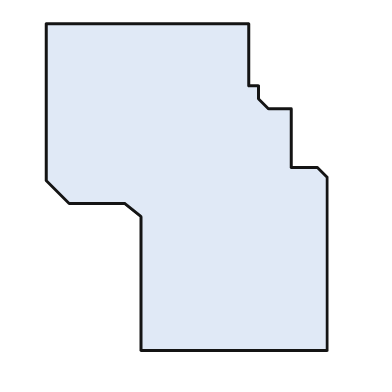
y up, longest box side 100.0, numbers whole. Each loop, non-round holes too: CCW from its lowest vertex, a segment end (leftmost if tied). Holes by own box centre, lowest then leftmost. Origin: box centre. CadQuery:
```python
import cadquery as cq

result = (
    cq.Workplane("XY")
    .moveTo(-14.0, -50.0)
    .lineTo(43.0, -50.0)
    .lineTo(43.0, 3.0)
    .lineTo(40.0, 6.0)
    .lineTo(32.0, 6.0)
    .lineTo(32.0, 24.0)
    .lineTo(25.0, 24.0)
    .lineTo(22.0, 27.0)
    .lineTo(22.0, 31.0)
    .lineTo(19.0, 31.0)
    .lineTo(19.0, 50.0)
    .lineTo(-43.0, 50.0)
    .lineTo(-43.0, 2.0)
    .lineTo(-36.0, -5.0)
    .lineTo(-19.0, -5.0)
    .lineTo(-14.0, -9.0)
    .close()
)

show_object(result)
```